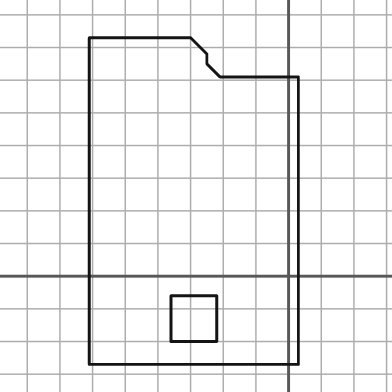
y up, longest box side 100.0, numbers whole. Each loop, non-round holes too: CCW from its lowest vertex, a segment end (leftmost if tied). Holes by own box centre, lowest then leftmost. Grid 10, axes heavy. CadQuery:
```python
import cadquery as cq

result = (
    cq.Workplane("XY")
    .moveTo(-61.0, -27.0)
    .lineTo(3.0, -27.0)
    .lineTo(3.0, 61.0)
    .lineTo(-21.0, 61.0)
    .lineTo(-25.0, 65.0)
    .lineTo(-25.0, 68.0)
    .lineTo(-30.0, 73.0)
    .lineTo(-61.0, 73.0)
    .close()
    .moveTo(-36.0, -20.0)
    .lineTo(-22.0, -20.0)
    .lineTo(-22.0, -6.0)
    .lineTo(-36.0, -6.0)
    .close()
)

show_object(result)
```